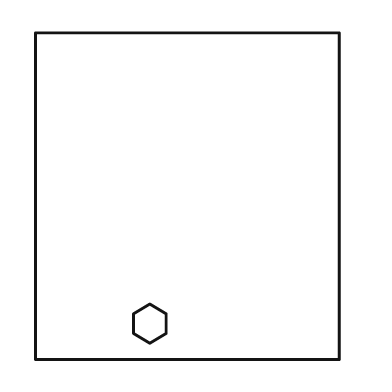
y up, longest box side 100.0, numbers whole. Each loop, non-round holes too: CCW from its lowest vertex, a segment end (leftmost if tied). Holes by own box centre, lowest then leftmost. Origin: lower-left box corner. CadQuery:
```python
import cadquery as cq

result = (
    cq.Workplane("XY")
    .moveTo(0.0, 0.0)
    .lineTo(93.0, 0.0)
    .lineTo(93.0, 100.0)
    .lineTo(0.0, 100.0)
    .close()
    .moveTo(35.0, 5.0)
    .lineTo(40.0, 8.0)
    .lineTo(40.0, 14.0)
    .lineTo(35.0, 17.0)
    .lineTo(30.0, 14.0)
    .lineTo(30.0, 8.0)
    .close()
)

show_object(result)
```